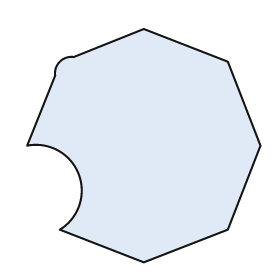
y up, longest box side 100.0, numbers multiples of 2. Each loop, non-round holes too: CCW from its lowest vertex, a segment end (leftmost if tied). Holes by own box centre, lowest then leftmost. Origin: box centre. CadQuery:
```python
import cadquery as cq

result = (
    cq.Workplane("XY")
    .moveTo(0.0, -50.0)
    .lineTo(36.0, -36.0)
    .lineTo(50.0, 0.0)
    .lineTo(36.0, 36.0)
    .lineTo(0.0, 50.0)
    .lineTo(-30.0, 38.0)
    .threePointArc((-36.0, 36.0), (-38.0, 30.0))
    .lineTo(-50.0, 0.0)
    .threePointArc((-28.0, -12.0), (-36.0, -36.0))
    .close()
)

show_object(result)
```